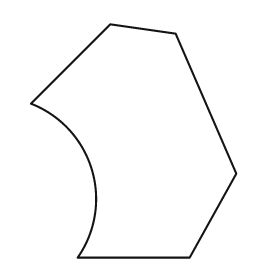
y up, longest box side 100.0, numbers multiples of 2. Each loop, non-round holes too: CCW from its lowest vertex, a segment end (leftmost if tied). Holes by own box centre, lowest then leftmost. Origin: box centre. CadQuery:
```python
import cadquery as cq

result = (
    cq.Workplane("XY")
    .moveTo(-24.0, -50.0)
    .lineTo(24.0, -50.0)
    .lineTo(44.0, -14.0)
    .lineTo(18.0, 46.0)
    .lineTo(-10.0, 50.0)
    .lineTo(-44.0, 16.0)
    .threePointArc((-18.0, -12.0), (-24.0, -50.0))
    .close()
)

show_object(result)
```